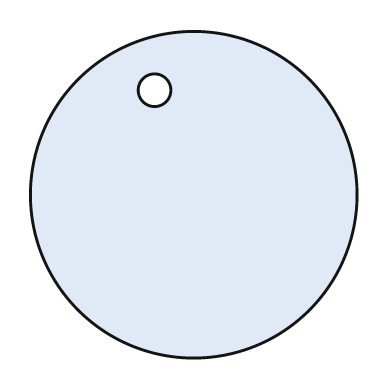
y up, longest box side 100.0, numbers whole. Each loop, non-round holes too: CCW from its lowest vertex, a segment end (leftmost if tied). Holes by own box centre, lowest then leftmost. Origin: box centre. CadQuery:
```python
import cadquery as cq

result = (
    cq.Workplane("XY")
    .moveTo(0.0, 0.0)
    .circle(50.0)
    .moveTo(-12.0, 32.0)
    .circle(5.0)
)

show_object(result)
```